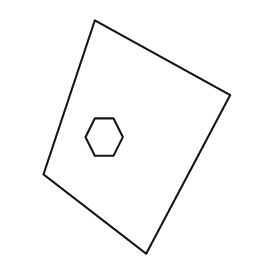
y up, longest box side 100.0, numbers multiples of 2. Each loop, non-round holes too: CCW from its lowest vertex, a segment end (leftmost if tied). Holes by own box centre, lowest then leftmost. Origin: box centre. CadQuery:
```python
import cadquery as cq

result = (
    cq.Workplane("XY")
    .moveTo(4.0, -50.0)
    .lineTo(40.0, 18.0)
    .lineTo(-18.0, 50.0)
    .lineTo(-40.0, -16.0)
    .close()
    .moveTo(-18.0, -8.0)
    .lineTo(-10.0, -8.0)
    .lineTo(-6.0, 0.0)
    .lineTo(-10.0, 8.0)
    .lineTo(-18.0, 8.0)
    .lineTo(-22.0, 0.0)
    .close()
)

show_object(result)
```